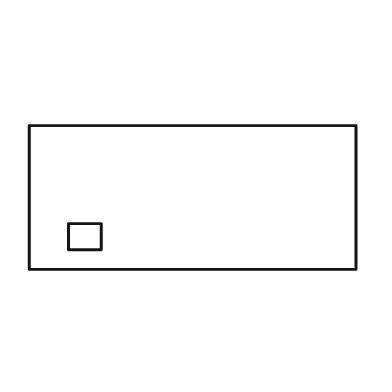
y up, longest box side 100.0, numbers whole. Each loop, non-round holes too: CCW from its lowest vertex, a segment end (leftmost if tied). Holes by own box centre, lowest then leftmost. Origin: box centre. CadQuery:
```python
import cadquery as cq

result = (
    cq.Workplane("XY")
    .moveTo(-50.0, -22.0)
    .lineTo(50.0, -22.0)
    .lineTo(50.0, 22.0)
    .lineTo(-50.0, 22.0)
    .close()
    .moveTo(-38.0, -16.0)
    .lineTo(-28.0, -16.0)
    .lineTo(-28.0, -8.0)
    .lineTo(-38.0, -8.0)
    .close()
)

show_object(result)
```